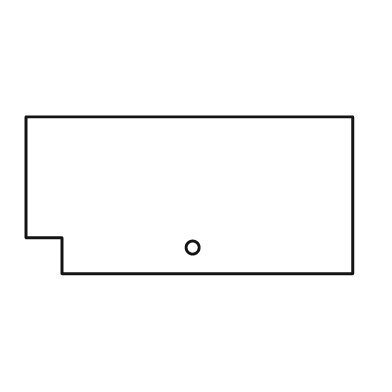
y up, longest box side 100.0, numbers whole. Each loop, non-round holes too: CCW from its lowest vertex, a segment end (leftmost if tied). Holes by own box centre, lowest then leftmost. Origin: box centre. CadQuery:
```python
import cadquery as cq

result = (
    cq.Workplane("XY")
    .moveTo(-39.0, -24.0)
    .lineTo(50.0, -24.0)
    .lineTo(50.0, 24.0)
    .lineTo(-50.0, 24.0)
    .lineTo(-50.0, -13.0)
    .lineTo(-39.0, -13.0)
    .close()
    .moveTo(1.0, -16.0)
    .circle(2.0)
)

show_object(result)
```